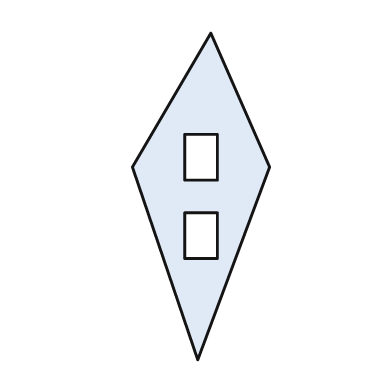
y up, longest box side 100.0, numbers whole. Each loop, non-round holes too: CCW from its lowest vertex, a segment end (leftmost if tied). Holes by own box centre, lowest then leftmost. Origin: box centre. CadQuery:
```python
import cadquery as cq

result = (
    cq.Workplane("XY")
    .moveTo(-1.0, -50.0)
    .lineTo(21.0, 9.0)
    .lineTo(3.0, 50.0)
    .lineTo(-21.0, 9.0)
    .close()
    .moveTo(-5.0, -19.0)
    .lineTo(5.0, -19.0)
    .lineTo(5.0, -5.0)
    .lineTo(-5.0, -5.0)
    .close()
    .moveTo(-5.0, 5.0)
    .lineTo(5.0, 5.0)
    .lineTo(5.0, 19.0)
    .lineTo(-5.0, 19.0)
    .close()
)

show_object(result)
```